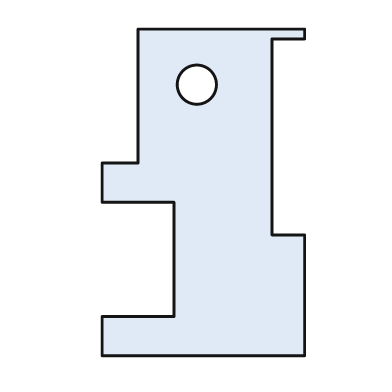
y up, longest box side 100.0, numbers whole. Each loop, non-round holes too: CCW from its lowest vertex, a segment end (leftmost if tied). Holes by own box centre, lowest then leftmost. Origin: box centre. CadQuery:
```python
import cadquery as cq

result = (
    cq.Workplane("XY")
    .moveTo(-31.0, -50.0)
    .lineTo(31.0, -50.0)
    .lineTo(31.0, -13.0)
    .lineTo(21.0, -13.0)
    .lineTo(21.0, 47.0)
    .lineTo(31.0, 47.0)
    .lineTo(31.0, 50.0)
    .lineTo(-20.0, 50.0)
    .lineTo(-20.0, 9.0)
    .lineTo(-31.0, 9.0)
    .lineTo(-31.0, -3.0)
    .lineTo(-9.0, -3.0)
    .lineTo(-9.0, -38.0)
    .lineTo(-31.0, -38.0)
    .close()
    .moveTo(-2.0, 33.0)
    .circle(6.0)
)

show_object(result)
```